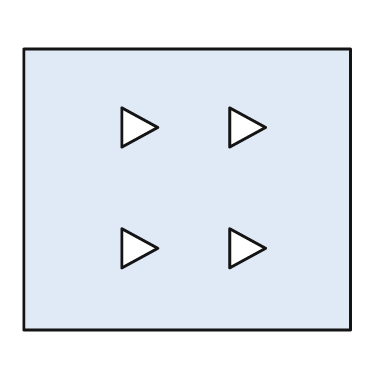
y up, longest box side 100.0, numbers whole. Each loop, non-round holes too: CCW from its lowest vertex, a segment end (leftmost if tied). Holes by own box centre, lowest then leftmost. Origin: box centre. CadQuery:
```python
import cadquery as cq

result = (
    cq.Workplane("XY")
    .moveTo(-50.0, -43.0)
    .lineTo(50.0, -43.0)
    .lineTo(50.0, 43.0)
    .lineTo(-50.0, 43.0)
    .close()
    .moveTo(-20.0, -24.0)
    .lineTo(-9.0, -18.0)
    .lineTo(-20.0, -12.0)
    .close()
    .moveTo(13.0, -24.0)
    .lineTo(24.0, -18.0)
    .lineTo(13.0, -12.0)
    .close()
    .moveTo(-20.0, 13.0)
    .lineTo(-9.0, 19.0)
    .lineTo(-20.0, 25.0)
    .close()
    .moveTo(13.0, 13.0)
    .lineTo(24.0, 19.0)
    .lineTo(13.0, 25.0)
    .close()
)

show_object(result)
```